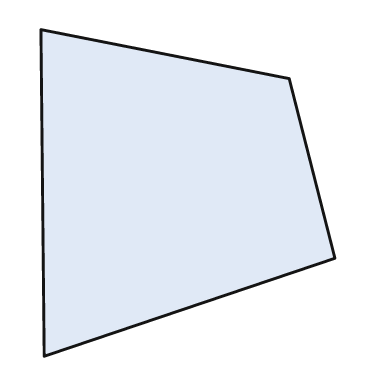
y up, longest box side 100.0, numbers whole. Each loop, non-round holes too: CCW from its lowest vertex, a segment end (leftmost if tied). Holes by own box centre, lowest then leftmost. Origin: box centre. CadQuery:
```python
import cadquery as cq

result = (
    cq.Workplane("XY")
    .moveTo(-44.0, -50.0)
    .lineTo(45.0, -20.0)
    .lineTo(31.0, 35.0)
    .lineTo(-45.0, 50.0)
    .close()
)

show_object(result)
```